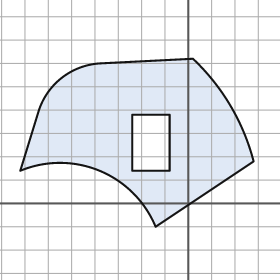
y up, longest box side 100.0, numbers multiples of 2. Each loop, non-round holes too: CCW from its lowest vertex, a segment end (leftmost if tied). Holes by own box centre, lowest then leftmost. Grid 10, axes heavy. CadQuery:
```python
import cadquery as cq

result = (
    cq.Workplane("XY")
    .moveTo(-14.0, -10.0)
    .lineTo(28.0, 18.0)
    .threePointArc((18.0, 42.0), (2.0, 62.0))
    .lineTo(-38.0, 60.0)
    .threePointArc((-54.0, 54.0), (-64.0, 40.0))
    .lineTo(-72.0, 14.0)
    .threePointArc((-38.0, 14.0), (-14.0, -10.0))
    .close()
    .moveTo(-24.0, 14.0)
    .lineTo(-8.0, 14.0)
    .lineTo(-8.0, 38.0)
    .lineTo(-24.0, 38.0)
    .close()
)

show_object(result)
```